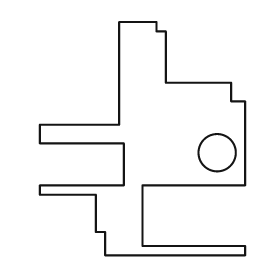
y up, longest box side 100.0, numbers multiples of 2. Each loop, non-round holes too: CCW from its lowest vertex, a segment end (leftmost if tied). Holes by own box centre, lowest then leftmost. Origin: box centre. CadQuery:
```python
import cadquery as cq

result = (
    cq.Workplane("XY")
    .moveTo(-16.0, -50.0)
    .lineTo(44.0, -50.0)
    .lineTo(44.0, -46.0)
    .lineTo(0.0, -46.0)
    .lineTo(0.0, -20.0)
    .lineTo(44.0, -20.0)
    .lineTo(44.0, 16.0)
    .lineTo(38.0, 16.0)
    .lineTo(38.0, 24.0)
    .lineTo(10.0, 24.0)
    .lineTo(10.0, 46.0)
    .lineTo(6.0, 46.0)
    .lineTo(6.0, 50.0)
    .lineTo(-10.0, 50.0)
    .lineTo(-10.0, 6.0)
    .lineTo(-44.0, 6.0)
    .lineTo(-44.0, -2.0)
    .lineTo(-8.0, -2.0)
    .lineTo(-8.0, -20.0)
    .lineTo(-44.0, -20.0)
    .lineTo(-44.0, -24.0)
    .lineTo(-20.0, -24.0)
    .lineTo(-20.0, -40.0)
    .lineTo(-16.0, -40.0)
    .close()
    .moveTo(32.0, -6.0)
    .circle(8.0)
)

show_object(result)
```